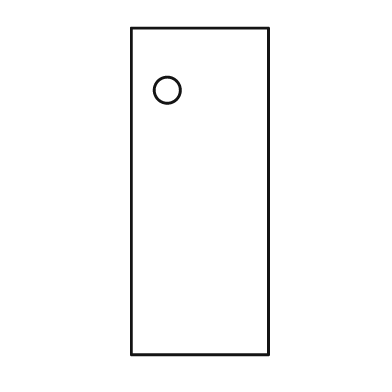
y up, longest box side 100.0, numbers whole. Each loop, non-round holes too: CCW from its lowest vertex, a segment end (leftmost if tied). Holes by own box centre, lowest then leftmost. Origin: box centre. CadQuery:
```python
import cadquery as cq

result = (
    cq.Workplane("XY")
    .moveTo(-21.0, -50.0)
    .lineTo(21.0, -50.0)
    .lineTo(21.0, 50.0)
    .lineTo(-21.0, 50.0)
    .close()
    .moveTo(-10.0, 31.0)
    .circle(4.0)
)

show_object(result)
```